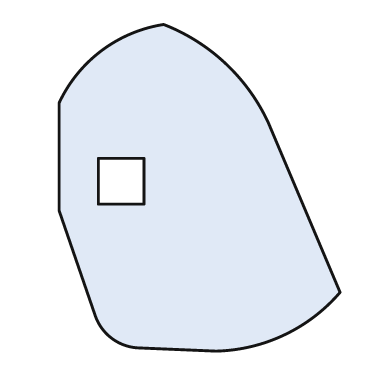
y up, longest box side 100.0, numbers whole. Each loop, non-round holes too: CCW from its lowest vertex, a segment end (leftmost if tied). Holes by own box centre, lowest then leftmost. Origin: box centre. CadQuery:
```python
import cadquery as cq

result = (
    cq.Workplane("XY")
    .moveTo(5.0, -50.0)
    .threePointArc((26.0, -45.0), (43.0, -32.0))
    .lineTo(21.0, 20.0)
    .threePointArc((8.0, 38.0), (-11.0, 50.0))
    .threePointArc((-30.0, 42.0), (-43.0, 26.0))
    .lineTo(-43.0, -7.0)
    .lineTo(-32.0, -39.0)
    .threePointArc((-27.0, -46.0), (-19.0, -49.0))
    .close()
    .moveTo(-31.0, -5.0)
    .lineTo(-17.0, -5.0)
    .lineTo(-17.0, 9.0)
    .lineTo(-31.0, 9.0)
    .close()
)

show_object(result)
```